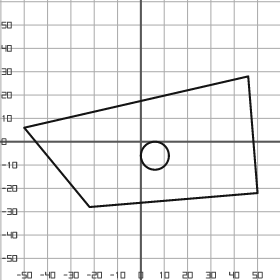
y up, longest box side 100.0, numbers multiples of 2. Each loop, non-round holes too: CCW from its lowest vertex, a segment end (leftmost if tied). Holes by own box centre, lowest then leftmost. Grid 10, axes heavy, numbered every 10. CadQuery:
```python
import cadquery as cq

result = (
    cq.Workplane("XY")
    .moveTo(-22.0, -28.0)
    .lineTo(50.0, -22.0)
    .lineTo(46.0, 28.0)
    .lineTo(-50.0, 6.0)
    .close()
    .moveTo(6.0, -6.0)
    .circle(6.0)
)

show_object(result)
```